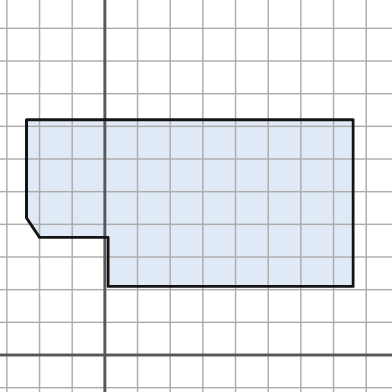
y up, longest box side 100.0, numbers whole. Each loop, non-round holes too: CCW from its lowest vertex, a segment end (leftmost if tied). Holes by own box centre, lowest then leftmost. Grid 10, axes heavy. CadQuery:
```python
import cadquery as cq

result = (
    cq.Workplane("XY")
    .moveTo(1.0, 21.0)
    .lineTo(76.0, 21.0)
    .lineTo(76.0, 72.0)
    .lineTo(-24.0, 72.0)
    .lineTo(-24.0, 42.0)
    .lineTo(-20.0, 36.0)
    .lineTo(1.0, 36.0)
    .close()
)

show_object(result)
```